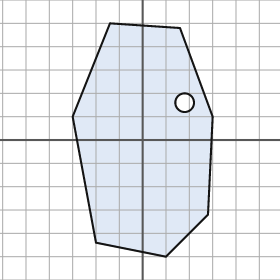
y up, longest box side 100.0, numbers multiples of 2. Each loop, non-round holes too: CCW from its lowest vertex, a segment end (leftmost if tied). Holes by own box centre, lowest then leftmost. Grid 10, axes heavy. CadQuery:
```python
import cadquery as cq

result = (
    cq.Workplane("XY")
    .moveTo(10.0, -50.0)
    .lineTo(28.0, -32.0)
    .lineTo(30.0, 10.0)
    .lineTo(16.0, 48.0)
    .lineTo(-14.0, 50.0)
    .lineTo(-30.0, 10.0)
    .lineTo(-20.0, -44.0)
    .close()
    .moveTo(18.0, 16.0)
    .circle(4.0)
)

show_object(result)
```